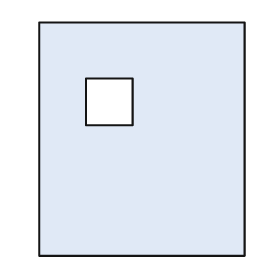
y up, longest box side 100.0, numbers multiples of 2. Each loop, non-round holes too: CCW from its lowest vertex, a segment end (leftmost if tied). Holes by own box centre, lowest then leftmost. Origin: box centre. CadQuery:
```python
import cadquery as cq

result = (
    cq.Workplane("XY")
    .moveTo(-44.0, -50.0)
    .lineTo(44.0, -50.0)
    .lineTo(44.0, 50.0)
    .lineTo(-44.0, 50.0)
    .close()
    .moveTo(-24.0, 6.0)
    .lineTo(-4.0, 6.0)
    .lineTo(-4.0, 26.0)
    .lineTo(-24.0, 26.0)
    .close()
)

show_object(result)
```